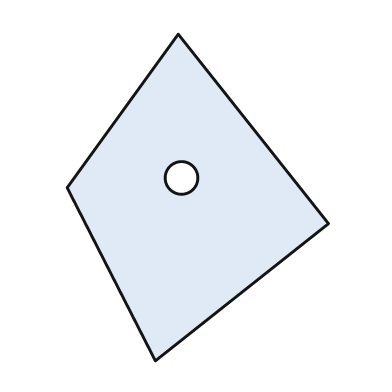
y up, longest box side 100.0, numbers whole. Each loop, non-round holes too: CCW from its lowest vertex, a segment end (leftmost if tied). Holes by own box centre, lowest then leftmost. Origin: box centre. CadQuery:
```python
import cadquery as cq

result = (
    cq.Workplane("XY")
    .moveTo(-13.0, -50.0)
    .lineTo(40.0, -8.0)
    .lineTo(-6.0, 50.0)
    .lineTo(-40.0, 3.0)
    .close()
    .moveTo(-5.0, 6.0)
    .circle(5.0)
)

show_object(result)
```